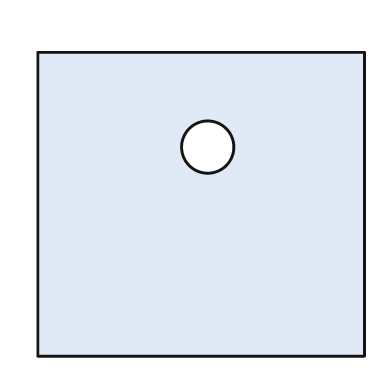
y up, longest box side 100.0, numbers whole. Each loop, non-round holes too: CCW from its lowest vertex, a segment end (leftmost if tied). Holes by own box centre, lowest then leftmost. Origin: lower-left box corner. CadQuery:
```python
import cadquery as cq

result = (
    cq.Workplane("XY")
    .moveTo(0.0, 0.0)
    .lineTo(100.0, 0.0)
    .lineTo(100.0, 93.0)
    .lineTo(0.0, 93.0)
    .close()
    .moveTo(52.0, 64.0)
    .circle(8.0)
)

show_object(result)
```